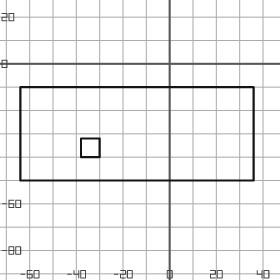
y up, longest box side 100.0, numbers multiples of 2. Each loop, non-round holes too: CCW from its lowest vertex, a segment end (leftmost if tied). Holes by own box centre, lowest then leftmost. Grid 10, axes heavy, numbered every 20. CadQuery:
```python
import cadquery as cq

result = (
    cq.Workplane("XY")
    .moveTo(-64.0, -50.0)
    .lineTo(36.0, -50.0)
    .lineTo(36.0, -10.0)
    .lineTo(-64.0, -10.0)
    .close()
    .moveTo(-38.0, -40.0)
    .lineTo(-30.0, -40.0)
    .lineTo(-30.0, -32.0)
    .lineTo(-38.0, -32.0)
    .close()
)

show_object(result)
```